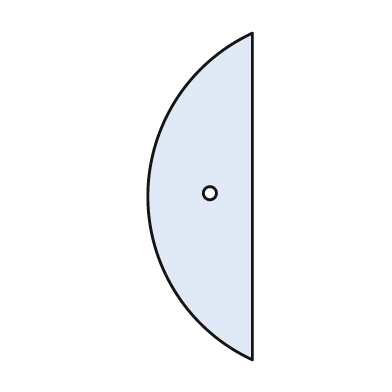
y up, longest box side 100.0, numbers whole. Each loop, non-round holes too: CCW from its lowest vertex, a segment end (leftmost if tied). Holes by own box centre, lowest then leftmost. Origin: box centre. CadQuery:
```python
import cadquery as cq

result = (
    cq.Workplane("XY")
    .moveTo(16.0, -50.0)
    .lineTo(16.0, 50.0)
    .threePointArc((-16.0, 0.0), (16.0, -50.0))
    .close()
    .moveTo(3.0, 1.0)
    .circle(2.0)
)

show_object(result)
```